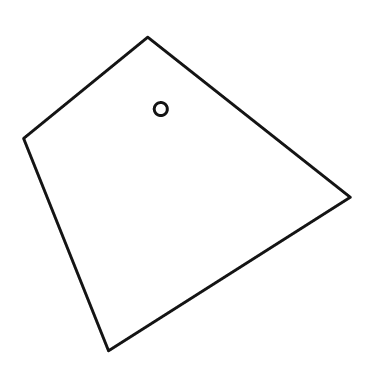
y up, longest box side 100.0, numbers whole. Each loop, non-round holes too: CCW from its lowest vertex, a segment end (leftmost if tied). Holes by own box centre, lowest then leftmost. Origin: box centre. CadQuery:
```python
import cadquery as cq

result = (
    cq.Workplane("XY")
    .moveTo(-24.0, -48.0)
    .lineTo(50.0, -1.0)
    .lineTo(-12.0, 48.0)
    .lineTo(-50.0, 17.0)
    .close()
    .moveTo(-8.0, 26.0)
    .circle(2.0)
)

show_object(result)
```